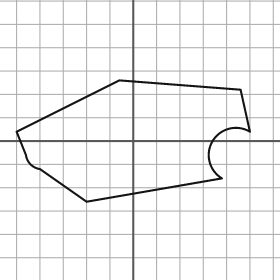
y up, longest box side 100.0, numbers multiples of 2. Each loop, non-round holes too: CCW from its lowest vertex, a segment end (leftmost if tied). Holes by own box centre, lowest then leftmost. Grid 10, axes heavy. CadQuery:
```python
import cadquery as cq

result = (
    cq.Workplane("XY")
    .moveTo(-20.0, -26.0)
    .lineTo(38.0, -16.0)
    .threePointArc((34.0, 0.0), (50.0, 4.0))
    .lineTo(46.0, 22.0)
    .lineTo(-6.0, 26.0)
    .lineTo(-50.0, 4.0)
    .lineTo(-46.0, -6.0)
    .threePointArc((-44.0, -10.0), (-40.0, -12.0))
    .close()
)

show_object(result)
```